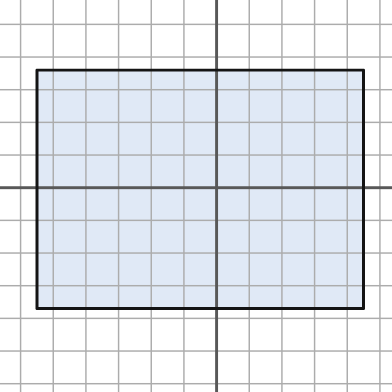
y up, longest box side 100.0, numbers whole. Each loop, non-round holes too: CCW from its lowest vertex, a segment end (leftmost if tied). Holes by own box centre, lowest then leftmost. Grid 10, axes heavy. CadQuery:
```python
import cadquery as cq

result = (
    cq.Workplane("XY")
    .moveTo(-55.0, -37.0)
    .lineTo(45.0, -37.0)
    .lineTo(45.0, 36.0)
    .lineTo(-55.0, 36.0)
    .close()
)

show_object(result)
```